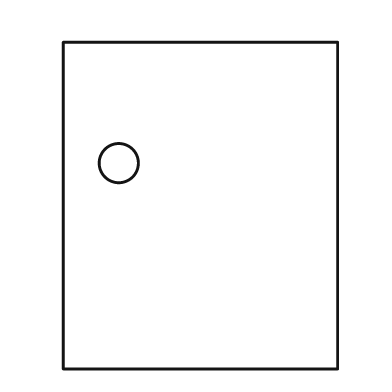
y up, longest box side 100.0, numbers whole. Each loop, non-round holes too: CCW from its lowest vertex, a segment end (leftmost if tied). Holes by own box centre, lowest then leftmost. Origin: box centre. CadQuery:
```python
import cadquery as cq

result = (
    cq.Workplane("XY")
    .moveTo(-42.0, -50.0)
    .lineTo(42.0, -50.0)
    .lineTo(42.0, 50.0)
    .lineTo(-42.0, 50.0)
    .close()
    .moveTo(-25.0, 13.0)
    .circle(6.0)
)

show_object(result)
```